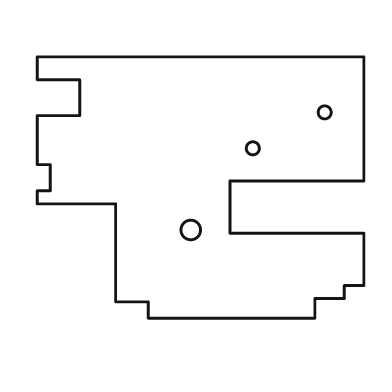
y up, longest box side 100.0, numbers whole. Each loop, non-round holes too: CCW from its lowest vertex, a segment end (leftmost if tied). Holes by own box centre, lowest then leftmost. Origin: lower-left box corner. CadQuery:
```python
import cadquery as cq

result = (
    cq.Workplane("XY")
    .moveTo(34.0, 0.0)
    .lineTo(85.0, 0.0)
    .lineTo(85.0, 6.0)
    .lineTo(94.0, 6.0)
    .lineTo(94.0, 10.0)
    .lineTo(100.0, 10.0)
    .lineTo(100.0, 26.0)
    .lineTo(59.0, 26.0)
    .lineTo(59.0, 42.0)
    .lineTo(100.0, 42.0)
    .lineTo(100.0, 80.0)
    .lineTo(0.0, 80.0)
    .lineTo(0.0, 73.0)
    .lineTo(13.0, 73.0)
    .lineTo(13.0, 62.0)
    .lineTo(0.0, 62.0)
    .lineTo(0.0, 47.0)
    .lineTo(4.0, 47.0)
    .lineTo(4.0, 39.0)
    .lineTo(0.0, 39.0)
    .lineTo(0.0, 35.0)
    .lineTo(24.0, 35.0)
    .lineTo(24.0, 5.0)
    .lineTo(34.0, 5.0)
    .close()
    .moveTo(47.0, 27.0)
    .circle(3.0)
    .moveTo(66.0, 52.0)
    .circle(2.0)
    .moveTo(88.0, 63.0)
    .circle(2.0)
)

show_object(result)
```